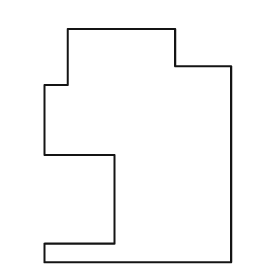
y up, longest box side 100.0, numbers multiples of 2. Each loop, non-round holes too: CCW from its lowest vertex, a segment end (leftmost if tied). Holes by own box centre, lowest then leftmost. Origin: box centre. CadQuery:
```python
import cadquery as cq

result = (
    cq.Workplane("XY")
    .moveTo(-40.0, -50.0)
    .lineTo(40.0, -50.0)
    .lineTo(40.0, 34.0)
    .lineTo(16.0, 34.0)
    .lineTo(16.0, 50.0)
    .lineTo(-30.0, 50.0)
    .lineTo(-30.0, 26.0)
    .lineTo(-40.0, 26.0)
    .lineTo(-40.0, -4.0)
    .lineTo(-10.0, -4.0)
    .lineTo(-10.0, -42.0)
    .lineTo(-40.0, -42.0)
    .close()
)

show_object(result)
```